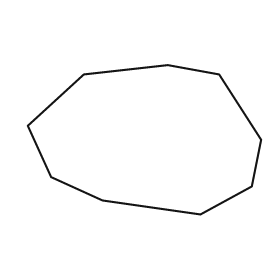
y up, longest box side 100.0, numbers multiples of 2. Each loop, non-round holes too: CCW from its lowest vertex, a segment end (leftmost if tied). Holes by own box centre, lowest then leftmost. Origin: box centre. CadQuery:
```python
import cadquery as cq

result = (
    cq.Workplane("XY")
    .moveTo(24.0, -32.0)
    .lineTo(46.0, -20.0)
    .lineTo(50.0, 0.0)
    .lineTo(32.0, 28.0)
    .lineTo(10.0, 32.0)
    .lineTo(-26.0, 28.0)
    .lineTo(-50.0, 6.0)
    .lineTo(-40.0, -16.0)
    .lineTo(-18.0, -26.0)
    .close()
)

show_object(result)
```